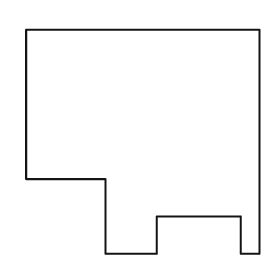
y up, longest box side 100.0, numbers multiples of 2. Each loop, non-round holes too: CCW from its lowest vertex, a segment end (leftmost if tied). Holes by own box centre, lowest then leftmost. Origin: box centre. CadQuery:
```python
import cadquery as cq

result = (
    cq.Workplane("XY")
    .moveTo(-16.0, -48.0)
    .lineTo(6.0, -48.0)
    .lineTo(6.0, -32.0)
    .lineTo(42.0, -32.0)
    .lineTo(42.0, -48.0)
    .lineTo(50.0, -48.0)
    .lineTo(50.0, 48.0)
    .lineTo(-50.0, 48.0)
    .lineTo(-50.0, -16.0)
    .lineTo(-16.0, -16.0)
    .close()
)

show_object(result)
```